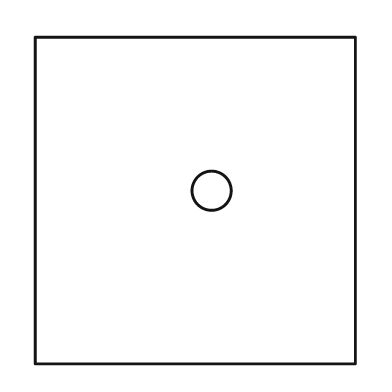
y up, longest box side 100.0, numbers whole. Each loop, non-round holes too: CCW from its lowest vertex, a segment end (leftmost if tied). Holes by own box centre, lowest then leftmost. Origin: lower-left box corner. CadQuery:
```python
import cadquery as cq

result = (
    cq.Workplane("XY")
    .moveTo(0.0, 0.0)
    .lineTo(98.0, 0.0)
    .lineTo(98.0, 100.0)
    .lineTo(0.0, 100.0)
    .close()
    .moveTo(54.0, 53.0)
    .circle(6.0)
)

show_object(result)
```